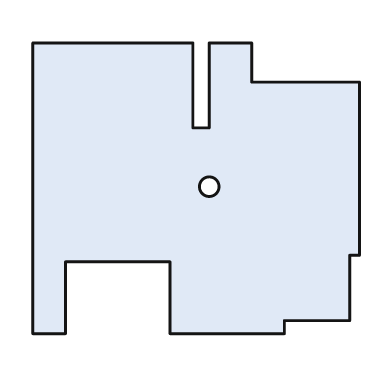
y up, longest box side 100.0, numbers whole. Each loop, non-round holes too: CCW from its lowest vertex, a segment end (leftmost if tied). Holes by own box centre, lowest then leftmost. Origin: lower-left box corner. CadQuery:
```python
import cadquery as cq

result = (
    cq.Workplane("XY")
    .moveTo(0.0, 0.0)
    .lineTo(10.0, 0.0)
    .lineTo(10.0, 22.0)
    .lineTo(42.0, 22.0)
    .lineTo(42.0, 0.0)
    .lineTo(77.0, 0.0)
    .lineTo(77.0, 4.0)
    .lineTo(97.0, 4.0)
    .lineTo(97.0, 24.0)
    .lineTo(100.0, 24.0)
    .lineTo(100.0, 77.0)
    .lineTo(67.0, 77.0)
    .lineTo(67.0, 89.0)
    .lineTo(54.0, 89.0)
    .lineTo(54.0, 63.0)
    .lineTo(49.0, 63.0)
    .lineTo(49.0, 89.0)
    .lineTo(0.0, 89.0)
    .close()
    .moveTo(54.0, 45.0)
    .circle(3.0)
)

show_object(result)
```